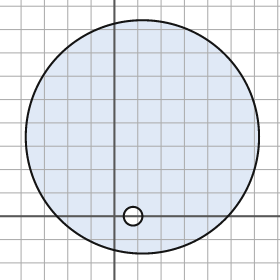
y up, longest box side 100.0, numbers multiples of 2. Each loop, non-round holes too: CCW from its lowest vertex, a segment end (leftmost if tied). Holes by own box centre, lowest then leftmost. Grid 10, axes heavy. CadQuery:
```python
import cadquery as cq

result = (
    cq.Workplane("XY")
    .moveTo(12.0, 34.0)
    .circle(50.0)
    .moveTo(8.0, 0.0)
    .circle(4.0)
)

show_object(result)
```